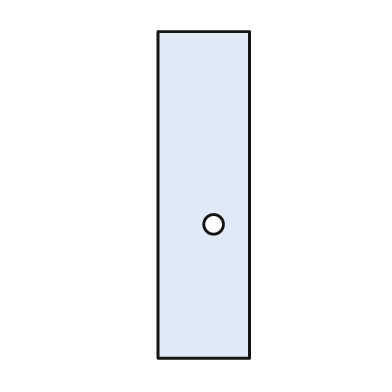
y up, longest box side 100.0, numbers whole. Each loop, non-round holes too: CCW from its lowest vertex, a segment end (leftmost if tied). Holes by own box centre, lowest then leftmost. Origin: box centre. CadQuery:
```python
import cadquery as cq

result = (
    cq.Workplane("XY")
    .moveTo(-14.0, -50.0)
    .lineTo(14.0, -50.0)
    .lineTo(14.0, 50.0)
    .lineTo(-14.0, 50.0)
    .close()
    .moveTo(3.0, -9.0)
    .circle(3.0)
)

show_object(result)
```